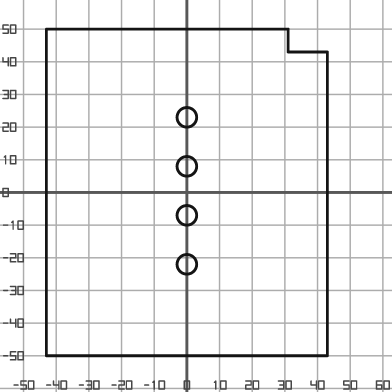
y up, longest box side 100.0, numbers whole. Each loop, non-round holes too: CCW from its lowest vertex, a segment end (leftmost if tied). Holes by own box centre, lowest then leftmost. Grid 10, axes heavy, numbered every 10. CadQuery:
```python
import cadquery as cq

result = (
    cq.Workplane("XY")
    .moveTo(-43.0, -50.0)
    .lineTo(43.0, -50.0)
    .lineTo(43.0, 43.0)
    .lineTo(31.0, 43.0)
    .lineTo(31.0, 50.0)
    .lineTo(-43.0, 50.0)
    .close()
    .moveTo(0.0, -22.0)
    .circle(3.0)
    .moveTo(0.0, -7.0)
    .circle(3.0)
    .moveTo(0.0, 8.0)
    .circle(3.0)
    .moveTo(0.0, 23.0)
    .circle(3.0)
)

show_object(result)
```